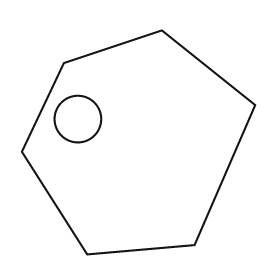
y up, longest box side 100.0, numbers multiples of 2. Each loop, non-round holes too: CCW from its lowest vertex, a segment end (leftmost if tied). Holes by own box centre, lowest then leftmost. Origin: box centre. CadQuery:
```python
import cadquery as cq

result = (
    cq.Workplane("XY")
    .moveTo(-22.0, -48.0)
    .lineTo(24.0, -44.0)
    .lineTo(50.0, 16.0)
    .lineTo(10.0, 48.0)
    .lineTo(-32.0, 34.0)
    .lineTo(-50.0, -4.0)
    .close()
    .moveTo(-26.0, 10.0)
    .circle(10.0)
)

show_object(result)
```